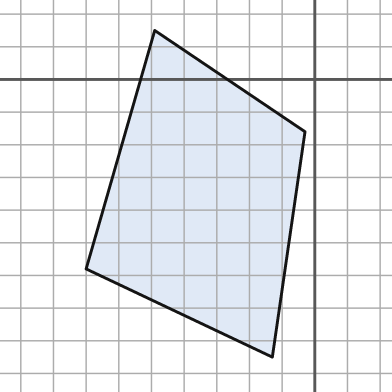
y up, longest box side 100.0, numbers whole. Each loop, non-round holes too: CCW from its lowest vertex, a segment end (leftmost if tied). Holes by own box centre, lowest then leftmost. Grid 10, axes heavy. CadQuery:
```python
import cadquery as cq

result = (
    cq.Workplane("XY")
    .moveTo(-13.0, -85.0)
    .lineTo(-3.0, -16.0)
    .lineTo(-49.0, 15.0)
    .lineTo(-70.0, -58.0)
    .close()
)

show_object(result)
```